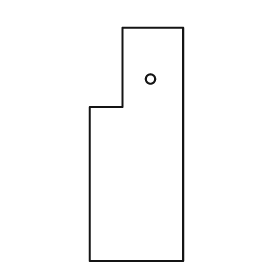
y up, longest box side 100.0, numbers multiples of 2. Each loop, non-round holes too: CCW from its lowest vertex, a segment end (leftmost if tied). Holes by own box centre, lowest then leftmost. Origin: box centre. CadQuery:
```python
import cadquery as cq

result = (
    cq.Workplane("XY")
    .moveTo(-20.0, -50.0)
    .lineTo(20.0, -50.0)
    .lineTo(20.0, 50.0)
    .lineTo(-6.0, 50.0)
    .lineTo(-6.0, 16.0)
    .lineTo(-20.0, 16.0)
    .close()
    .moveTo(6.0, 28.0)
    .circle(2.0)
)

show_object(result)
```